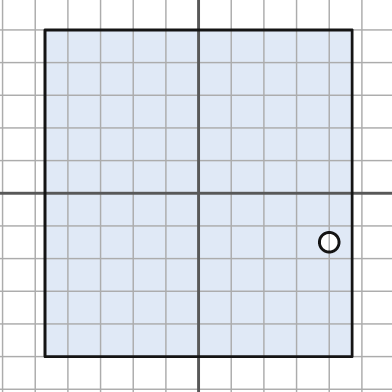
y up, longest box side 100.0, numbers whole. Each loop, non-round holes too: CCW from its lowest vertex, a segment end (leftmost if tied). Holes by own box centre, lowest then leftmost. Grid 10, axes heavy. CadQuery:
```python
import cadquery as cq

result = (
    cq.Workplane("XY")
    .moveTo(-47.0, -50.0)
    .lineTo(47.0, -50.0)
    .lineTo(47.0, 50.0)
    .lineTo(-47.0, 50.0)
    .close()
    .moveTo(40.0, -15.0)
    .circle(3.0)
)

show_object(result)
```